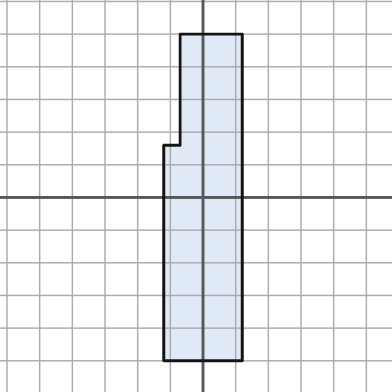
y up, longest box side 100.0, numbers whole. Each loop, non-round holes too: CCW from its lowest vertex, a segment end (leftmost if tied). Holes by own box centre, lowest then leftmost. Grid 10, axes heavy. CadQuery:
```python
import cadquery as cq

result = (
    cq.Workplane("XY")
    .moveTo(-12.0, -50.0)
    .lineTo(12.0, -50.0)
    .lineTo(12.0, 50.0)
    .lineTo(-7.0, 50.0)
    .lineTo(-7.0, 16.0)
    .lineTo(-12.0, 16.0)
    .close()
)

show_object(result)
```